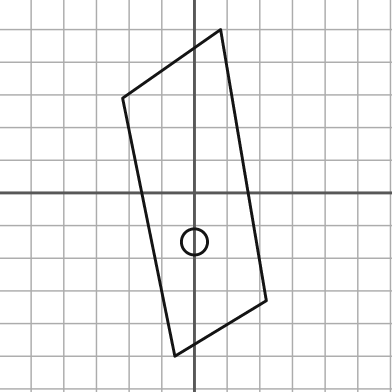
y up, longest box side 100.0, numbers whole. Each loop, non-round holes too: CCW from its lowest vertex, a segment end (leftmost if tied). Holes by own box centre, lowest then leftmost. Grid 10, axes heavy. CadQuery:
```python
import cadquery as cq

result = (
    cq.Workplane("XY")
    .moveTo(-6.0, -50.0)
    .lineTo(22.0, -33.0)
    .lineTo(8.0, 50.0)
    .lineTo(-22.0, 29.0)
    .close()
    .moveTo(0.0, -15.0)
    .circle(4.0)
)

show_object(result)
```